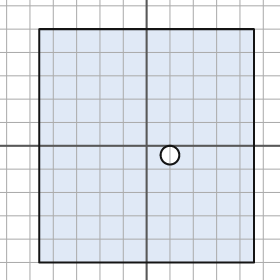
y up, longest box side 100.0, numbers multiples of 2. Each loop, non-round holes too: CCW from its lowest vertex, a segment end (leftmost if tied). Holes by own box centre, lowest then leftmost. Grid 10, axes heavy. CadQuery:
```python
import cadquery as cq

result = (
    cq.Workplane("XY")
    .moveTo(-46.0, -50.0)
    .lineTo(46.0, -50.0)
    .lineTo(46.0, 50.0)
    .lineTo(-46.0, 50.0)
    .close()
    .moveTo(10.0, -4.0)
    .circle(4.0)
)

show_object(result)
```